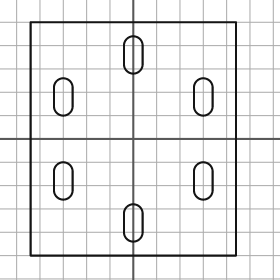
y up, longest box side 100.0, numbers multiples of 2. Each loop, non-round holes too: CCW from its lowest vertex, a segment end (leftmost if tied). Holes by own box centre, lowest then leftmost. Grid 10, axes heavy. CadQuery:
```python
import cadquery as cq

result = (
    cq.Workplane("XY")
    .moveTo(-44.0, -50.0)
    .lineTo(44.0, -50.0)
    .lineTo(44.0, 50.0)
    .lineTo(-44.0, 50.0)
    .close()
    .moveTo(-4.0, -40.0)
    .threePointArc((0.0, -44.0), (4.0, -40.0))
    .lineTo(4.0, -32.0)
    .threePointArc((0.0, -28.0), (-4.0, -32.0))
    .close()
    .moveTo(-34.0, -22.0)
    .threePointArc((-30.0, -26.0), (-26.0, -22.0))
    .lineTo(-26.0, -14.0)
    .threePointArc((-30.0, -10.0), (-34.0, -14.0))
    .close()
    .moveTo(26.0, -22.0)
    .threePointArc((30.0, -26.0), (34.0, -22.0))
    .lineTo(34.0, -14.0)
    .threePointArc((30.0, -10.0), (26.0, -14.0))
    .close()
    .moveTo(-34.0, 14.0)
    .threePointArc((-30.0, 10.0), (-26.0, 14.0))
    .lineTo(-26.0, 22.0)
    .threePointArc((-30.0, 26.0), (-34.0, 22.0))
    .close()
    .moveTo(26.0, 14.0)
    .threePointArc((30.0, 10.0), (34.0, 14.0))
    .lineTo(34.0, 22.0)
    .threePointArc((30.0, 26.0), (26.0, 22.0))
    .close()
    .moveTo(-4.0, 32.0)
    .threePointArc((0.0, 28.0), (4.0, 32.0))
    .lineTo(4.0, 40.0)
    .threePointArc((0.0, 44.0), (-4.0, 40.0))
    .close()
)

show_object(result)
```